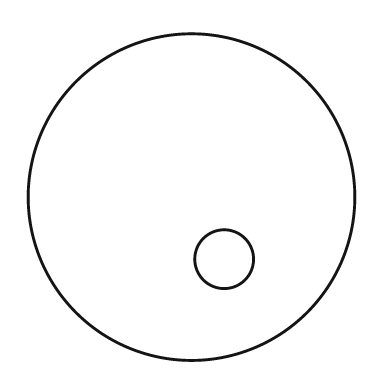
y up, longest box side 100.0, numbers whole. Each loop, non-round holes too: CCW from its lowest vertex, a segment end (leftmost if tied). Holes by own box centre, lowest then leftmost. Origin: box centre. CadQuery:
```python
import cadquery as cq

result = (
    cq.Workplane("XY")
    .moveTo(0.0, 0.0)
    .circle(50.0)
    .moveTo(10.0, -19.0)
    .circle(9.0)
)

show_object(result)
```